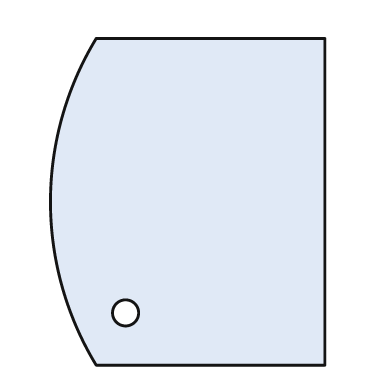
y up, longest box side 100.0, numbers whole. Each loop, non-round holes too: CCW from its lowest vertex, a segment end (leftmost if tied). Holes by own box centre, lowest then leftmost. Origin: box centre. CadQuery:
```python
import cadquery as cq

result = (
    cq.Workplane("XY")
    .moveTo(-28.0, -50.0)
    .lineTo(42.0, -50.0)
    .lineTo(42.0, 50.0)
    .lineTo(-28.0, 50.0)
    .threePointArc((-42.0, 0.0), (-28.0, -50.0))
    .close()
    .moveTo(-19.0, -34.0)
    .circle(4.0)
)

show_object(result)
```